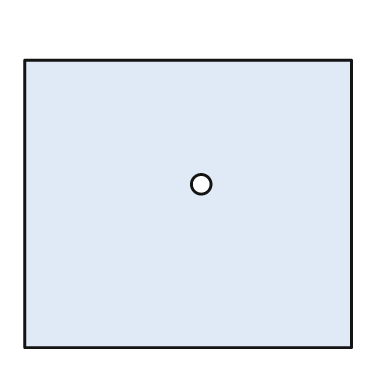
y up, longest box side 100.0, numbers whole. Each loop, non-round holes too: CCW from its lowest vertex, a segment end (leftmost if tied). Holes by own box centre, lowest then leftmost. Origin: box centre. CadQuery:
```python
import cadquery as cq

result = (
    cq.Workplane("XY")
    .moveTo(-50.0, -44.0)
    .lineTo(50.0, -44.0)
    .lineTo(50.0, 44.0)
    .lineTo(-50.0, 44.0)
    .close()
    .moveTo(4.0, 6.0)
    .circle(3.0)
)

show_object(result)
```